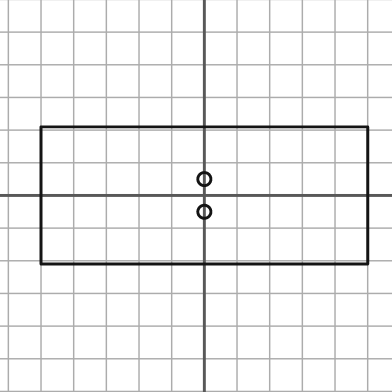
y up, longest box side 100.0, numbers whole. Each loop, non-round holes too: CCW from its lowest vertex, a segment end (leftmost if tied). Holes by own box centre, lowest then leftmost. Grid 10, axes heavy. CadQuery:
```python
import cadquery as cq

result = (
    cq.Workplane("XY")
    .moveTo(-50.0, -21.0)
    .lineTo(50.0, -21.0)
    .lineTo(50.0, 21.0)
    .lineTo(-50.0, 21.0)
    .close()
    .moveTo(0.0, -5.0)
    .circle(2.0)
    .moveTo(0.0, 5.0)
    .circle(2.0)
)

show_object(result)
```